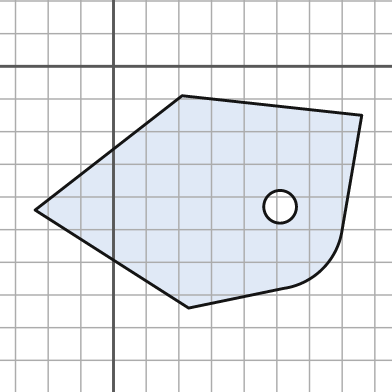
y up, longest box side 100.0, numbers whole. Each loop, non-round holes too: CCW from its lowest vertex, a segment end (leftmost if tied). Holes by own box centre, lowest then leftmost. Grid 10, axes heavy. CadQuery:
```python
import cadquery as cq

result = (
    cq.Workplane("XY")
    .moveTo(23.0, -74.0)
    .lineTo(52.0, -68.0)
    .threePointArc((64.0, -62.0), (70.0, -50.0))
    .lineTo(76.0, -15.0)
    .lineTo(21.0, -9.0)
    .lineTo(-24.0, -44.0)
    .close()
    .moveTo(51.0, -43.0)
    .circle(5.0)
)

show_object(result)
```